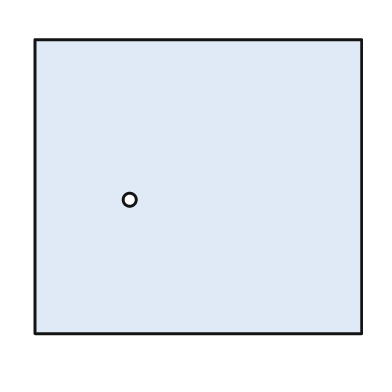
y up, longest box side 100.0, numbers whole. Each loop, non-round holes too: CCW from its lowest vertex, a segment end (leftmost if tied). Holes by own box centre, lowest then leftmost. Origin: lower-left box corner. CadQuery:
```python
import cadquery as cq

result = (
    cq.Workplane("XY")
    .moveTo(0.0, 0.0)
    .lineTo(100.0, 0.0)
    .lineTo(100.0, 90.0)
    .lineTo(0.0, 90.0)
    .close()
    .moveTo(29.0, 41.0)
    .circle(2.0)
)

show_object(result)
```